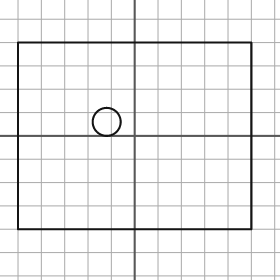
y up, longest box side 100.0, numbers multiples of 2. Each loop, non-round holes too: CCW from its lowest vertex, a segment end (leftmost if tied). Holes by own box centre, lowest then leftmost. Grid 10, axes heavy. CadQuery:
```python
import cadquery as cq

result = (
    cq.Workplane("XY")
    .moveTo(-50.0, -40.0)
    .lineTo(50.0, -40.0)
    .lineTo(50.0, 40.0)
    .lineTo(-50.0, 40.0)
    .close()
    .moveTo(-12.0, 6.0)
    .circle(6.0)
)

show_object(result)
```